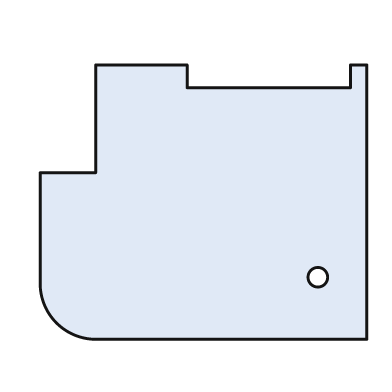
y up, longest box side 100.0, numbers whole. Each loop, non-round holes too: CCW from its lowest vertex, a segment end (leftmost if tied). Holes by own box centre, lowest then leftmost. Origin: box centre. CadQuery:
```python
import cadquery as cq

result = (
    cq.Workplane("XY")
    .moveTo(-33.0, -42.0)
    .lineTo(50.0, -42.0)
    .lineTo(50.0, 42.0)
    .lineTo(45.0, 42.0)
    .lineTo(45.0, 35.0)
    .lineTo(-5.0, 35.0)
    .lineTo(-5.0, 42.0)
    .lineTo(-33.0, 42.0)
    .lineTo(-33.0, 9.0)
    .lineTo(-50.0, 9.0)
    .lineTo(-50.0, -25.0)
    .threePointArc((-45.0, -37.0), (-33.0, -42.0))
    .close()
    .moveTo(35.0, -23.0)
    .circle(3.0)
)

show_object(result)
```